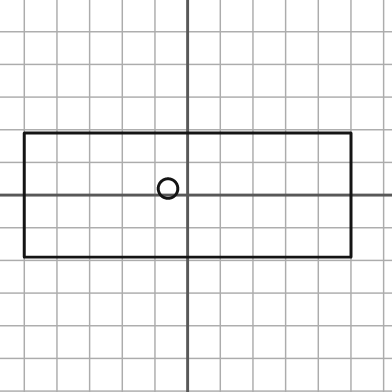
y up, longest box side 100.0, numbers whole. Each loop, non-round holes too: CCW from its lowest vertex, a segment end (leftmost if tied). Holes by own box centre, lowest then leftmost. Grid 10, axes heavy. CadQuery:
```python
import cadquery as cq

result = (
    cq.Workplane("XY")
    .moveTo(-50.0, -19.0)
    .lineTo(50.0, -19.0)
    .lineTo(50.0, 19.0)
    .lineTo(-50.0, 19.0)
    .close()
    .moveTo(-6.0, 2.0)
    .circle(3.0)
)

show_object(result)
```